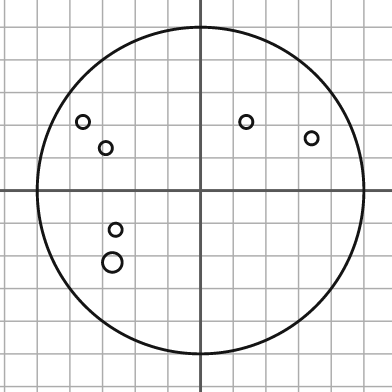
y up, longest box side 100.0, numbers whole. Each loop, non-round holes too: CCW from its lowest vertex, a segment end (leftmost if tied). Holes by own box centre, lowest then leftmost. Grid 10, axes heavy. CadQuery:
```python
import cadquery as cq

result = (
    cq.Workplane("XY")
    .moveTo(0.0, 0.0)
    .circle(50.0)
    .moveTo(-27.0, -22.0)
    .circle(3.0)
    .moveTo(-26.0, -12.0)
    .circle(2.0)
    .moveTo(-29.0, 13.0)
    .circle(2.0)
    .moveTo(34.0, 16.0)
    .circle(2.0)
    .moveTo(-36.0, 21.0)
    .circle(2.0)
    .moveTo(14.0, 21.0)
    .circle(2.0)
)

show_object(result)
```